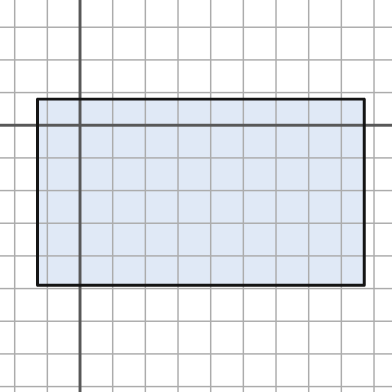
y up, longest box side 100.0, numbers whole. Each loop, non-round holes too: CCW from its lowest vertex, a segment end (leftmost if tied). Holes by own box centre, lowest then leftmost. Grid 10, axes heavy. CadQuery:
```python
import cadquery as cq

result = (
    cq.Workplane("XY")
    .moveTo(-13.0, -49.0)
    .lineTo(87.0, -49.0)
    .lineTo(87.0, 8.0)
    .lineTo(-13.0, 8.0)
    .close()
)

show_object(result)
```